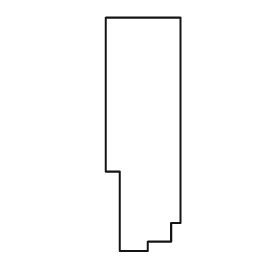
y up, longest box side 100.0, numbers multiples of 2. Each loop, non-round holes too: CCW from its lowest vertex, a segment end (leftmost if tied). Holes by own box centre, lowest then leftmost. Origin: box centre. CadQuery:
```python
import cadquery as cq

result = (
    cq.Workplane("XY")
    .moveTo(-10.0, -50.0)
    .lineTo(2.0, -50.0)
    .lineTo(2.0, -46.0)
    .lineTo(12.0, -46.0)
    .lineTo(12.0, -38.0)
    .lineTo(16.0, -38.0)
    .lineTo(16.0, 50.0)
    .lineTo(-16.0, 50.0)
    .lineTo(-16.0, -16.0)
    .lineTo(-10.0, -16.0)
    .close()
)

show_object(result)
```